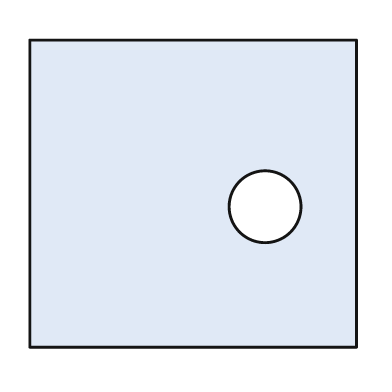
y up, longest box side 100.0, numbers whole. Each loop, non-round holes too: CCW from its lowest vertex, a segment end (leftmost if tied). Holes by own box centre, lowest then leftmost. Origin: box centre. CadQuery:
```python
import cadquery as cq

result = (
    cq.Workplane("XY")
    .moveTo(-50.0, -47.0)
    .lineTo(50.0, -47.0)
    .lineTo(50.0, 47.0)
    .lineTo(-50.0, 47.0)
    .close()
    .moveTo(22.0, -4.0)
    .circle(11.0)
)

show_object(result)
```